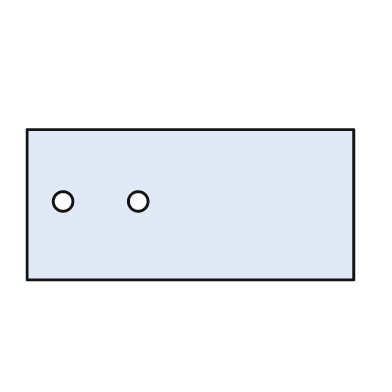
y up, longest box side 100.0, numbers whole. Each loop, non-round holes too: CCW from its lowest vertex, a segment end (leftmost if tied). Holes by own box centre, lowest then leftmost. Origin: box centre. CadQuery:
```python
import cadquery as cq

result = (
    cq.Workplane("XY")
    .moveTo(-50.0, -23.0)
    .lineTo(50.0, -23.0)
    .lineTo(50.0, 23.0)
    .lineTo(-50.0, 23.0)
    .close()
    .moveTo(-39.0, 1.0)
    .circle(3.0)
    .moveTo(-16.0, 1.0)
    .circle(3.0)
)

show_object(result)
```